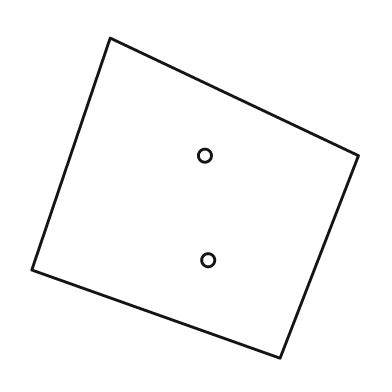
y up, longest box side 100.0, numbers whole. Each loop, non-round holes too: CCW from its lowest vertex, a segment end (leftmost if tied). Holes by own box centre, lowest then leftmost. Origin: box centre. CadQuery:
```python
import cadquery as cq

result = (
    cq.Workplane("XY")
    .moveTo(26.0, -49.0)
    .lineTo(50.0, 13.0)
    .lineTo(-26.0, 49.0)
    .lineTo(-50.0, -22.0)
    .close()
    .moveTo(4.0, -19.0)
    .circle(2.0)
    .moveTo(3.0, 13.0)
    .circle(2.0)
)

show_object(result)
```